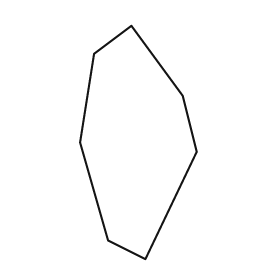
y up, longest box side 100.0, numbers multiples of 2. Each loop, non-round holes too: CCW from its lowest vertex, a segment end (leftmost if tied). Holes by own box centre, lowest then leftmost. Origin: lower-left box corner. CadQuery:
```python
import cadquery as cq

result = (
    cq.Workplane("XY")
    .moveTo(28.0, 0.0)
    .lineTo(50.0, 46.0)
    .lineTo(44.0, 70.0)
    .lineTo(22.0, 100.0)
    .lineTo(6.0, 88.0)
    .lineTo(0.0, 50.0)
    .lineTo(12.0, 8.0)
    .close()
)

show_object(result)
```